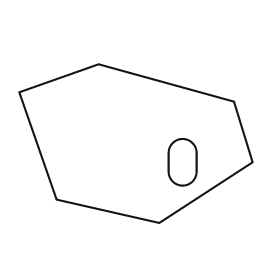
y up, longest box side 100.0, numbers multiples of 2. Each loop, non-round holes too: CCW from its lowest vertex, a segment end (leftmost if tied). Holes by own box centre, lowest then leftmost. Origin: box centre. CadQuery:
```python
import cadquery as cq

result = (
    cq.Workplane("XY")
    .moveTo(10.0, -34.0)
    .lineTo(50.0, -8.0)
    .lineTo(42.0, 18.0)
    .lineTo(-16.0, 34.0)
    .lineTo(-50.0, 22.0)
    .lineTo(-34.0, -24.0)
    .close()
    .moveTo(14.0, -12.0)
    .threePointArc((20.0, -18.0), (26.0, -12.0))
    .lineTo(26.0, -4.0)
    .threePointArc((20.0, 2.0), (14.0, -4.0))
    .close()
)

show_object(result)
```